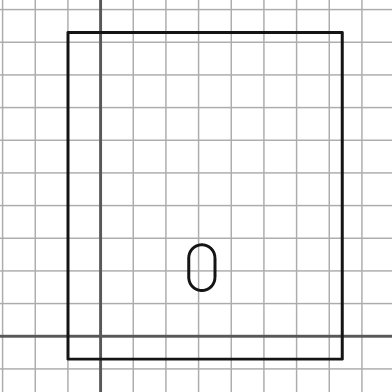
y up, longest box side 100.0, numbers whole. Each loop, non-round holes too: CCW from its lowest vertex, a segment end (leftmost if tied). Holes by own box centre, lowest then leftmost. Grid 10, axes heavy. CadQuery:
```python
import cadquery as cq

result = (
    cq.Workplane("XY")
    .moveTo(-10.0, -7.0)
    .lineTo(74.0, -7.0)
    .lineTo(74.0, 93.0)
    .lineTo(-10.0, 93.0)
    .close()
    .moveTo(27.0, 18.0)
    .threePointArc((31.0, 14.0), (35.0, 18.0))
    .lineTo(35.0, 24.0)
    .threePointArc((31.0, 28.0), (27.0, 24.0))
    .close()
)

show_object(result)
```